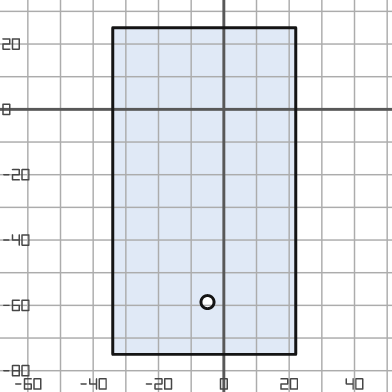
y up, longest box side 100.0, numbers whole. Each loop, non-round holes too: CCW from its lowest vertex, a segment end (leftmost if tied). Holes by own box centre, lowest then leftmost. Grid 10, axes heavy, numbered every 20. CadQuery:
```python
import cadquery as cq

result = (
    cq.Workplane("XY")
    .moveTo(-34.0, -75.0)
    .lineTo(22.0, -75.0)
    .lineTo(22.0, 25.0)
    .lineTo(-34.0, 25.0)
    .close()
    .moveTo(-5.0, -59.0)
    .circle(2.0)
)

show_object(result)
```